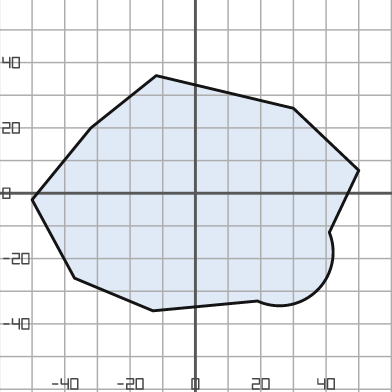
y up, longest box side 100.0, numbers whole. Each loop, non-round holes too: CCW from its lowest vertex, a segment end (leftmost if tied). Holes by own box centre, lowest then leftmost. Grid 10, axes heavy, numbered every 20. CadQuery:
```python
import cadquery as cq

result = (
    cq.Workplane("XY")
    .moveTo(-13.0, -36.0)
    .lineTo(19.0, -33.0)
    .threePointArc((37.0, -30.0), (41.0, -12.0))
    .lineTo(50.0, 7.0)
    .lineTo(30.0, 26.0)
    .lineTo(-12.0, 36.0)
    .lineTo(-32.0, 20.0)
    .lineTo(-50.0, -2.0)
    .lineTo(-37.0, -26.0)
    .close()
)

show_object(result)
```